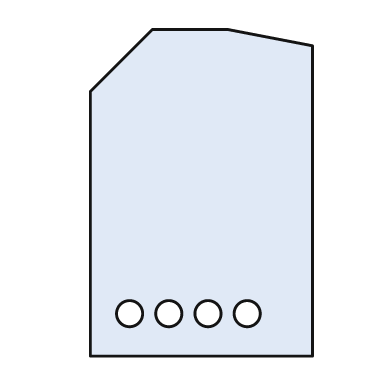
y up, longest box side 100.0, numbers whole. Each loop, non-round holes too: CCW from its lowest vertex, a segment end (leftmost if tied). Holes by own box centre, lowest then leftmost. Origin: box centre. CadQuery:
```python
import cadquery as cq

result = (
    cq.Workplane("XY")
    .moveTo(-34.0, -50.0)
    .lineTo(34.0, -50.0)
    .lineTo(34.0, 45.0)
    .lineTo(8.0, 50.0)
    .lineTo(-15.0, 50.0)
    .lineTo(-34.0, 31.0)
    .close()
    .moveTo(-22.0, -37.0)
    .circle(4.0)
    .moveTo(-10.0, -37.0)
    .circle(4.0)
    .moveTo(2.0, -37.0)
    .circle(4.0)
    .moveTo(14.0, -37.0)
    .circle(4.0)
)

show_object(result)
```